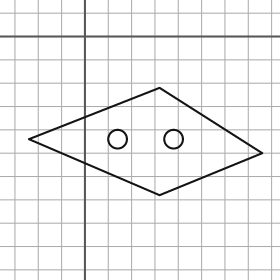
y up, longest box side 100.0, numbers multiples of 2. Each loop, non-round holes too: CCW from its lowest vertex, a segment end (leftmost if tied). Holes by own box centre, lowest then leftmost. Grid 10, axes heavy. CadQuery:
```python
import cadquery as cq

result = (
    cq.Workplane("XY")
    .moveTo(32.0, -68.0)
    .lineTo(76.0, -50.0)
    .lineTo(32.0, -22.0)
    .lineTo(-24.0, -44.0)
    .close()
    .moveTo(14.0, -44.0)
    .circle(4.0)
    .moveTo(38.0, -44.0)
    .circle(4.0)
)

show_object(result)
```